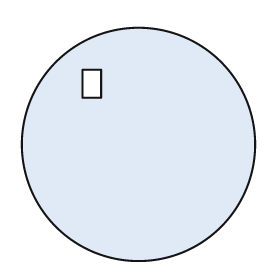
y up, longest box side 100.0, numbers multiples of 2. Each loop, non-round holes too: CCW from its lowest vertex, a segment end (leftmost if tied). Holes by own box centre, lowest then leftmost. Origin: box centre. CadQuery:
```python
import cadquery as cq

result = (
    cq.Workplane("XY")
    .moveTo(0.0, 0.0)
    .circle(50.0)
    .moveTo(-24.0, 20.0)
    .lineTo(-16.0, 20.0)
    .lineTo(-16.0, 32.0)
    .lineTo(-24.0, 32.0)
    .close()
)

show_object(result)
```